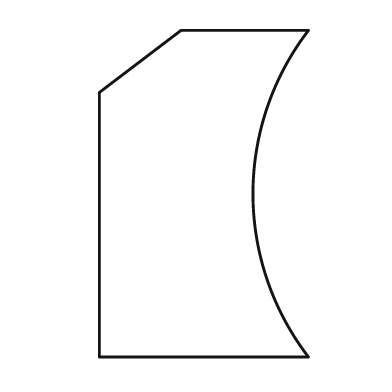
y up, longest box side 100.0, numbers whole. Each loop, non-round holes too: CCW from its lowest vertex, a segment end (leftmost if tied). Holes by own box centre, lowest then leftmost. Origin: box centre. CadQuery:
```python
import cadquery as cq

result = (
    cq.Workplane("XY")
    .moveTo(-32.0, -50.0)
    .lineTo(32.0, -50.0)
    .threePointArc((15.0, 0.0), (32.0, 50.0))
    .lineTo(-7.0, 50.0)
    .lineTo(-32.0, 31.0)
    .close()
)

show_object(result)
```